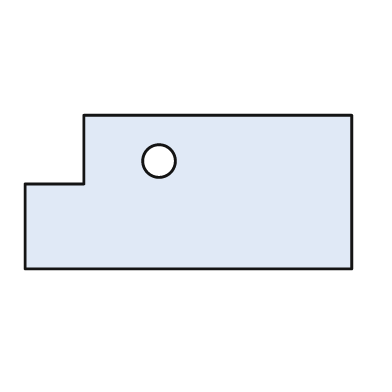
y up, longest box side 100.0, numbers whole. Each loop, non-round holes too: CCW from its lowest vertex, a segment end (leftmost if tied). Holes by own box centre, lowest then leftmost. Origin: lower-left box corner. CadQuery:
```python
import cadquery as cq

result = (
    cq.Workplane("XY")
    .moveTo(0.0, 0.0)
    .lineTo(100.0, 0.0)
    .lineTo(100.0, 47.0)
    .lineTo(18.0, 47.0)
    .lineTo(18.0, 26.0)
    .lineTo(0.0, 26.0)
    .close()
    .moveTo(41.0, 33.0)
    .circle(5.0)
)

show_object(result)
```